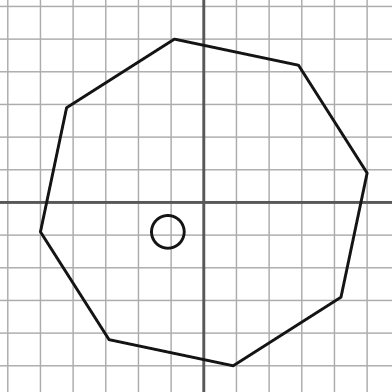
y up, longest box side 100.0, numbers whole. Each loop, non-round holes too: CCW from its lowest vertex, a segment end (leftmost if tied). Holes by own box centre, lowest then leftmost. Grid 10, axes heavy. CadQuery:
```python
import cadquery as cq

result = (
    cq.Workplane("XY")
    .moveTo(9.0, -50.0)
    .lineTo(42.0, -29.0)
    .lineTo(50.0, 9.0)
    .lineTo(29.0, 42.0)
    .lineTo(-9.0, 50.0)
    .lineTo(-42.0, 29.0)
    .lineTo(-50.0, -9.0)
    .lineTo(-29.0, -42.0)
    .close()
    .moveTo(-11.0, -9.0)
    .circle(5.0)
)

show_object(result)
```